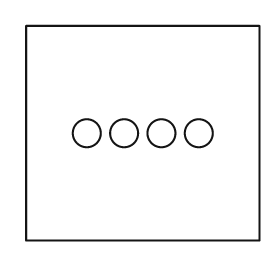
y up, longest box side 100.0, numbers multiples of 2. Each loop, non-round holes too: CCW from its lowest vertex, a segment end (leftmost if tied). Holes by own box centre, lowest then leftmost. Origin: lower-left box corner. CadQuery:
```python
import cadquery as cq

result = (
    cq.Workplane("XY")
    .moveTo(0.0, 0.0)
    .lineTo(100.0, 0.0)
    .lineTo(100.0, 92.0)
    .lineTo(0.0, 92.0)
    .close()
    .moveTo(26.0, 46.0)
    .circle(6.0)
    .moveTo(42.0, 46.0)
    .circle(6.0)
    .moveTo(58.0, 46.0)
    .circle(6.0)
    .moveTo(74.0, 46.0)
    .circle(6.0)
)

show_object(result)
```